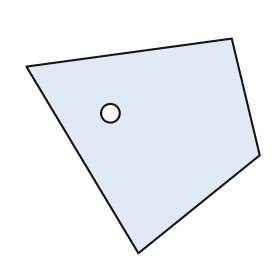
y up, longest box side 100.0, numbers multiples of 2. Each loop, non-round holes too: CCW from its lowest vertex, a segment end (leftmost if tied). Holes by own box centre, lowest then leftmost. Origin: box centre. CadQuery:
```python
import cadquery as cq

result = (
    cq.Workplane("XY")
    .moveTo(-2.0, -46.0)
    .lineTo(50.0, -4.0)
    .lineTo(38.0, 46.0)
    .lineTo(-50.0, 34.0)
    .close()
    .moveTo(-14.0, 14.0)
    .circle(4.0)
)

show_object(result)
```